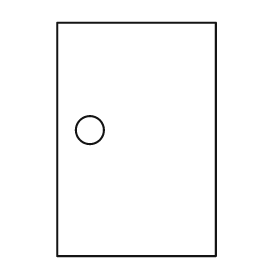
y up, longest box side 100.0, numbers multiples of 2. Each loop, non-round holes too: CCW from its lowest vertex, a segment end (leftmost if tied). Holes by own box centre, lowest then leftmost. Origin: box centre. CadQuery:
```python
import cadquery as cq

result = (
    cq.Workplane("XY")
    .moveTo(-34.0, -50.0)
    .lineTo(34.0, -50.0)
    .lineTo(34.0, 50.0)
    .lineTo(-34.0, 50.0)
    .close()
    .moveTo(-20.0, 4.0)
    .circle(6.0)
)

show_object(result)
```